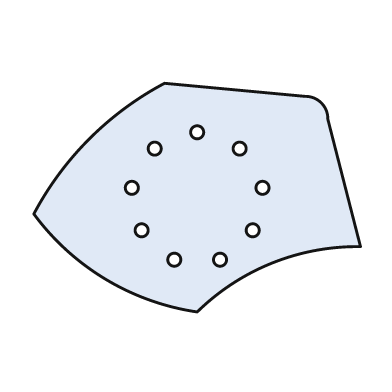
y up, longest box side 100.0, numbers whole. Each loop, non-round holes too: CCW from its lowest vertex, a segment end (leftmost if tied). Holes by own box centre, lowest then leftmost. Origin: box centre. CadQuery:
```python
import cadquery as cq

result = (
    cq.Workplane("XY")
    .moveTo(0.0, -35.0)
    .threePointArc((23.0, -20.0), (50.0, -15.0))
    .lineTo(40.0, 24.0)
    .threePointArc((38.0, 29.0), (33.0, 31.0))
    .lineTo(-10.0, 35.0)
    .threePointArc((-33.0, 18.0), (-50.0, -5.0))
    .threePointArc((-28.0, -25.0), (0.0, -35.0))
    .close()
    .moveTo(-7.0, -19.0)
    .circle(2.0)
    .moveTo(7.0, -19.0)
    .circle(2.0)
    .moveTo(-17.0, -10.0)
    .circle(2.0)
    .moveTo(17.0, -10.0)
    .circle(2.0)
    .moveTo(-20.0, 3.0)
    .circle(2.0)
    .moveTo(20.0, 3.0)
    .circle(2.0)
    .moveTo(-13.0, 15.0)
    .circle(2.0)
    .moveTo(13.0, 15.0)
    .circle(2.0)
    .moveTo(0.0, 20.0)
    .circle(2.0)
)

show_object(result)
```